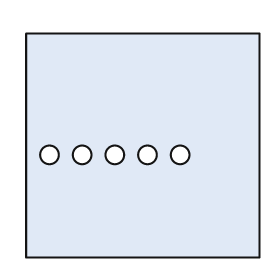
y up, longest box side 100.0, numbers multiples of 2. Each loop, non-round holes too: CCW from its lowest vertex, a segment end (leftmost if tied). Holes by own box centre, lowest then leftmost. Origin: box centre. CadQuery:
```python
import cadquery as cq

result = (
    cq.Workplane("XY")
    .moveTo(-50.0, -48.0)
    .lineTo(50.0, -48.0)
    .lineTo(50.0, 48.0)
    .lineTo(-50.0, 48.0)
    .close()
    .moveTo(-40.0, -4.0)
    .circle(4.0)
    .moveTo(-26.0, -4.0)
    .circle(4.0)
    .moveTo(-12.0, -4.0)
    .circle(4.0)
    .moveTo(2.0, -4.0)
    .circle(4.0)
    .moveTo(16.0, -4.0)
    .circle(4.0)
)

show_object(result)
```